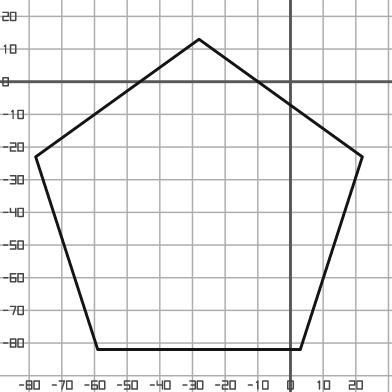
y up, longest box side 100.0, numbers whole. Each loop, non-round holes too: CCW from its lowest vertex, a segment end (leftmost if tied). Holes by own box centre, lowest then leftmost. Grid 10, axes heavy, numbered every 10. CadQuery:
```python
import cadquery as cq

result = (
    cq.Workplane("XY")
    .moveTo(-59.0, -82.0)
    .lineTo(3.0, -82.0)
    .lineTo(22.0, -23.0)
    .lineTo(-28.0, 13.0)
    .lineTo(-78.0, -23.0)
    .close()
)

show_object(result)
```